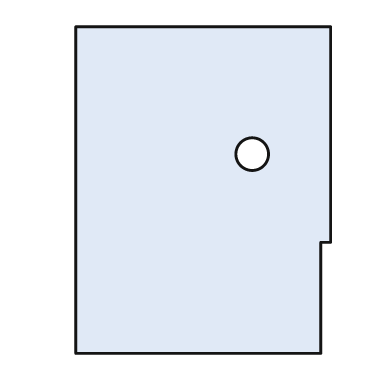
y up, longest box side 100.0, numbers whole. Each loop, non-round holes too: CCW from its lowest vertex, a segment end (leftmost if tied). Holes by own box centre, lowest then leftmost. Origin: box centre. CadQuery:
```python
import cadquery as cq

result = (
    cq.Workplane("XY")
    .moveTo(-39.0, -50.0)
    .lineTo(36.0, -50.0)
    .lineTo(36.0, -16.0)
    .lineTo(39.0, -16.0)
    .lineTo(39.0, 50.0)
    .lineTo(-39.0, 50.0)
    .close()
    .moveTo(15.0, 11.0)
    .circle(5.0)
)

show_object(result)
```